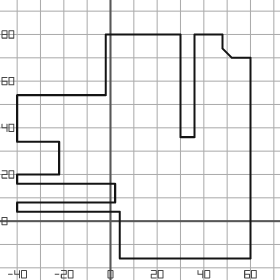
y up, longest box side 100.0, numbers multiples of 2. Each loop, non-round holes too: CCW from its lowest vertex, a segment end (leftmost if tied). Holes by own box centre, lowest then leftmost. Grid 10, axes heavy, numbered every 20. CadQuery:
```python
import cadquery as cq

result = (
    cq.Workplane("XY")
    .moveTo(4.0, -16.0)
    .lineTo(60.0, -16.0)
    .lineTo(60.0, 70.0)
    .lineTo(52.0, 70.0)
    .lineTo(48.0, 74.0)
    .lineTo(48.0, 80.0)
    .lineTo(36.0, 80.0)
    .lineTo(36.0, 36.0)
    .lineTo(30.0, 36.0)
    .lineTo(30.0, 80.0)
    .lineTo(-2.0, 80.0)
    .lineTo(-2.0, 54.0)
    .lineTo(-40.0, 54.0)
    .lineTo(-40.0, 34.0)
    .lineTo(-22.0, 34.0)
    .lineTo(-22.0, 20.0)
    .lineTo(-40.0, 20.0)
    .lineTo(-40.0, 16.0)
    .lineTo(2.0, 16.0)
    .lineTo(2.0, 8.0)
    .lineTo(-40.0, 8.0)
    .lineTo(-40.0, 4.0)
    .lineTo(4.0, 4.0)
    .close()
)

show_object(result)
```